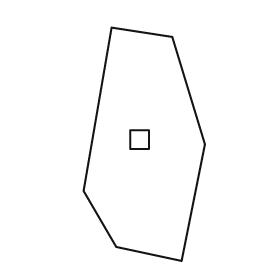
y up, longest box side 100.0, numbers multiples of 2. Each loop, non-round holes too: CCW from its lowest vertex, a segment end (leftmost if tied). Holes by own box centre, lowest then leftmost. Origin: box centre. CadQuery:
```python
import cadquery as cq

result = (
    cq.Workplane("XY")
    .moveTo(16.0, -50.0)
    .lineTo(26.0, 0.0)
    .lineTo(12.0, 46.0)
    .lineTo(-14.0, 50.0)
    .lineTo(-26.0, -20.0)
    .lineTo(-12.0, -44.0)
    .close()
    .moveTo(-6.0, -2.0)
    .lineTo(2.0, -2.0)
    .lineTo(2.0, 6.0)
    .lineTo(-6.0, 6.0)
    .close()
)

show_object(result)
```